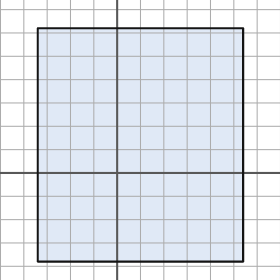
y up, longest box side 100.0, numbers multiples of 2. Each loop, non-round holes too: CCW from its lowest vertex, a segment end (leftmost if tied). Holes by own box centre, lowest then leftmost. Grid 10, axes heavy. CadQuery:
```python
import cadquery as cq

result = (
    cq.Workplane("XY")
    .moveTo(-34.0, -38.0)
    .lineTo(54.0, -38.0)
    .lineTo(54.0, 62.0)
    .lineTo(-34.0, 62.0)
    .close()
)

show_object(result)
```